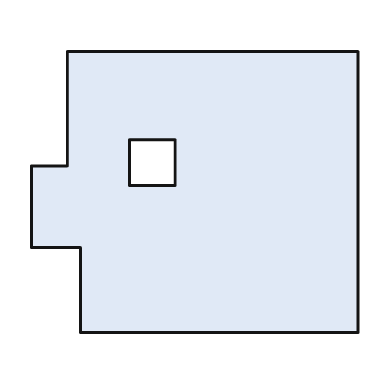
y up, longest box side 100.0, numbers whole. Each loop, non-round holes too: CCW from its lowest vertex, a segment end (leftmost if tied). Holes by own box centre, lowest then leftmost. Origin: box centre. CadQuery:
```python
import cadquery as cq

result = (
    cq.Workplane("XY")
    .moveTo(-35.0, -43.0)
    .lineTo(50.0, -43.0)
    .lineTo(50.0, 43.0)
    .lineTo(-39.0, 43.0)
    .lineTo(-39.0, 8.0)
    .lineTo(-50.0, 8.0)
    .lineTo(-50.0, -17.0)
    .lineTo(-35.0, -17.0)
    .close()
    .moveTo(-20.0, 2.0)
    .lineTo(-6.0, 2.0)
    .lineTo(-6.0, 16.0)
    .lineTo(-20.0, 16.0)
    .close()
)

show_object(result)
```